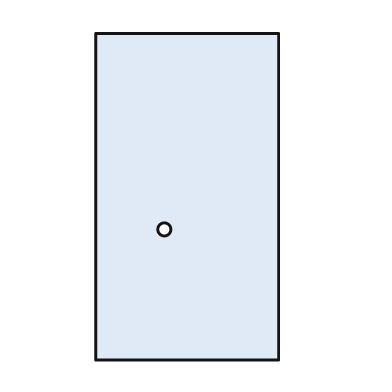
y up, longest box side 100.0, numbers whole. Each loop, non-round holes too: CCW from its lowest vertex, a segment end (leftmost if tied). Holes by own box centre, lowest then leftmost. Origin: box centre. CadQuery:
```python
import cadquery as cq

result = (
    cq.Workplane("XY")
    .moveTo(-28.0, -50.0)
    .lineTo(28.0, -50.0)
    .lineTo(28.0, 50.0)
    .lineTo(-28.0, 50.0)
    .close()
    .moveTo(-7.0, -10.0)
    .circle(2.0)
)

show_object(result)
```